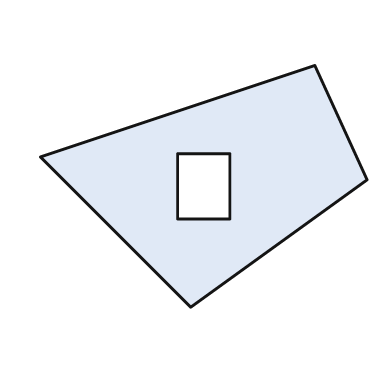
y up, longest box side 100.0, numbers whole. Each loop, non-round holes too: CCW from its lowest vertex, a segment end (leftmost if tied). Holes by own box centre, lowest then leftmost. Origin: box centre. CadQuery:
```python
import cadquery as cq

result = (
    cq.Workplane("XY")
    .moveTo(-4.0, -37.0)
    .lineTo(50.0, 2.0)
    .lineTo(34.0, 37.0)
    .lineTo(-50.0, 9.0)
    .close()
    .moveTo(-8.0, -10.0)
    .lineTo(8.0, -10.0)
    .lineTo(8.0, 10.0)
    .lineTo(-8.0, 10.0)
    .close()
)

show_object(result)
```